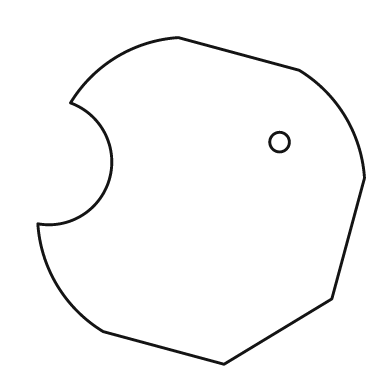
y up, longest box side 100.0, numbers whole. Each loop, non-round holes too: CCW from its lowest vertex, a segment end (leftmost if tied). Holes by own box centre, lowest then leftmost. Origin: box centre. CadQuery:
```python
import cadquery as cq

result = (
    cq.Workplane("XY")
    .moveTo(7.0, -50.0)
    .lineTo(40.0, -30.0)
    .lineTo(50.0, 7.0)
    .threePointArc((44.0, 26.0), (30.0, 40.0))
    .lineTo(-7.0, 50.0)
    .threePointArc((-26.0, 44.0), (-40.0, 30.0))
    .threePointArc((-28.0, 7.0), (-50.0, -7.0))
    .threePointArc((-44.0, -26.0), (-30.0, -40.0))
    .close()
    .moveTo(24.0, 18.0)
    .circle(3.0)
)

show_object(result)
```